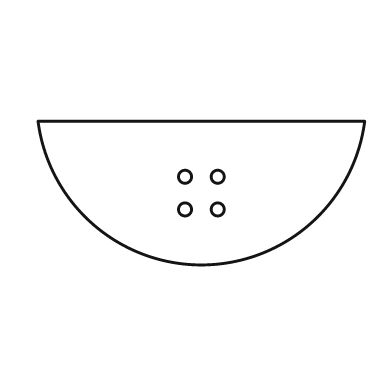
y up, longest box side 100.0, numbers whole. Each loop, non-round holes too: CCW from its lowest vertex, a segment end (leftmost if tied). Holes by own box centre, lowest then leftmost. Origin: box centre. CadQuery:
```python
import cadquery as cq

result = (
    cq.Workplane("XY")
    .moveTo(-50.0, 22.0)
    .threePointArc((0.0, -22.0), (50.0, 22.0))
    .close()
    .moveTo(-5.0, -5.0)
    .circle(2.0)
    .moveTo(5.0, -5.0)
    .circle(2.0)
    .moveTo(-5.0, 5.0)
    .circle(2.0)
    .moveTo(5.0, 5.0)
    .circle(2.0)
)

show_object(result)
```